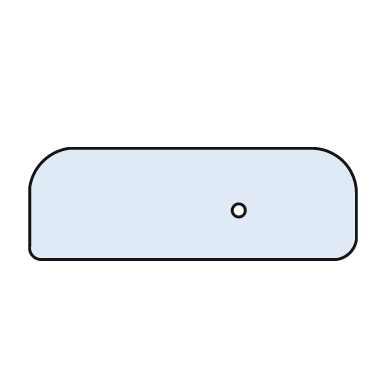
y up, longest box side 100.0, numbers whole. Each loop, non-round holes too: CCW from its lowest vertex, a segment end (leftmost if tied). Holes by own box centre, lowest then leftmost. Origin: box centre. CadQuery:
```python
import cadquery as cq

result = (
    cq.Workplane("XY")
    .moveTo(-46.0, -17.0)
    .lineTo(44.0, -17.0)
    .threePointArc((48.0, -15.0), (50.0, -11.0))
    .lineTo(50.0, 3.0)
    .threePointArc((46.0, 13.0), (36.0, 17.0))
    .lineTo(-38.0, 17.0)
    .threePointArc((-46.0, 13.0), (-50.0, 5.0))
    .lineTo(-50.0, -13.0)
    .threePointArc((-49.0, -16.0), (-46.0, -17.0))
    .close()
    .moveTo(14.0, -2.0)
    .circle(2.0)
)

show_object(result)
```